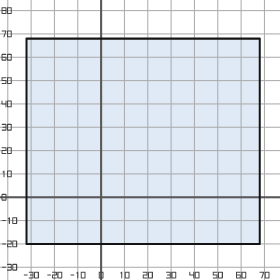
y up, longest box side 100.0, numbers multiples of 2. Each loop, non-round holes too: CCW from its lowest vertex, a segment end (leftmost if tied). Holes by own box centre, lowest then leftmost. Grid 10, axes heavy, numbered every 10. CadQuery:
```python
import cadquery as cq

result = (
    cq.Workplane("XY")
    .moveTo(-32.0, -20.0)
    .lineTo(68.0, -20.0)
    .lineTo(68.0, 68.0)
    .lineTo(-32.0, 68.0)
    .close()
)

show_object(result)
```